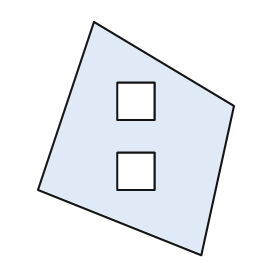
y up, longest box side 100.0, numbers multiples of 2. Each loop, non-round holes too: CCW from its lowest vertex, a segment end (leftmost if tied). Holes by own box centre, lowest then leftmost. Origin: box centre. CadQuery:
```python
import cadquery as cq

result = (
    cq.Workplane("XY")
    .moveTo(28.0, -50.0)
    .lineTo(42.0, 14.0)
    .lineTo(-18.0, 50.0)
    .lineTo(-42.0, -22.0)
    .close()
    .moveTo(-8.0, -22.0)
    .lineTo(8.0, -22.0)
    .lineTo(8.0, -6.0)
    .lineTo(-8.0, -6.0)
    .close()
    .moveTo(-8.0, 8.0)
    .lineTo(8.0, 8.0)
    .lineTo(8.0, 24.0)
    .lineTo(-8.0, 24.0)
    .close()
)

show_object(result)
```